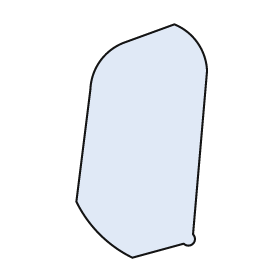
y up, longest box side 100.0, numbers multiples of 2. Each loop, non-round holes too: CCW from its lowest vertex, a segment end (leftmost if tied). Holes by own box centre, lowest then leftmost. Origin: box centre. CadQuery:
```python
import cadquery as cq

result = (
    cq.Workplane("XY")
    .moveTo(-4.0, -50.0)
    .lineTo(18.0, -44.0)
    .threePointArc((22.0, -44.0), (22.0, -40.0))
    .lineTo(28.0, 30.0)
    .threePointArc((24.0, 42.0), (14.0, 50.0))
    .lineTo(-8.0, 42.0)
    .threePointArc((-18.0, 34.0), (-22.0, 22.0))
    .lineTo(-28.0, -26.0)
    .threePointArc((-18.0, -40.0), (-4.0, -50.0))
    .close()
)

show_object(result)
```